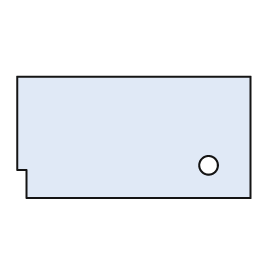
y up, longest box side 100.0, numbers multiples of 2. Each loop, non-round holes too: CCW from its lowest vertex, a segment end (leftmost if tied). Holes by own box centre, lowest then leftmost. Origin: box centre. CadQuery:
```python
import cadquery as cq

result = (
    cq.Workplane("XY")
    .moveTo(-46.0, -26.0)
    .lineTo(50.0, -26.0)
    .lineTo(50.0, 26.0)
    .lineTo(-50.0, 26.0)
    .lineTo(-50.0, -14.0)
    .lineTo(-46.0, -14.0)
    .close()
    .moveTo(32.0, -12.0)
    .circle(4.0)
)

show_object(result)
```